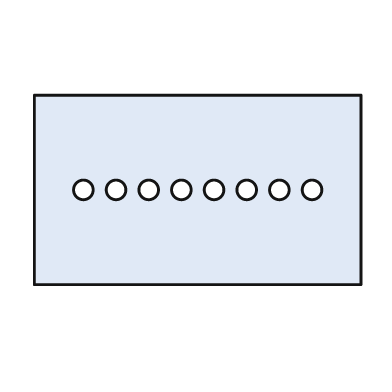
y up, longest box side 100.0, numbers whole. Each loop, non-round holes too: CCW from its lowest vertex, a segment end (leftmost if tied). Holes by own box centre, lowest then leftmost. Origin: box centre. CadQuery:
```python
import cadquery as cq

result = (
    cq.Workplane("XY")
    .moveTo(-50.0, -29.0)
    .lineTo(50.0, -29.0)
    .lineTo(50.0, 29.0)
    .lineTo(-50.0, 29.0)
    .close()
    .moveTo(-35.0, 0.0)
    .circle(3.0)
    .moveTo(-25.0, 0.0)
    .circle(3.0)
    .moveTo(-15.0, 0.0)
    .circle(3.0)
    .moveTo(-5.0, 0.0)
    .circle(3.0)
    .moveTo(5.0, 0.0)
    .circle(3.0)
    .moveTo(15.0, 0.0)
    .circle(3.0)
    .moveTo(25.0, 0.0)
    .circle(3.0)
    .moveTo(35.0, 0.0)
    .circle(3.0)
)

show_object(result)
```